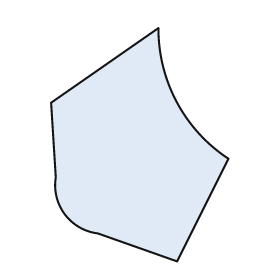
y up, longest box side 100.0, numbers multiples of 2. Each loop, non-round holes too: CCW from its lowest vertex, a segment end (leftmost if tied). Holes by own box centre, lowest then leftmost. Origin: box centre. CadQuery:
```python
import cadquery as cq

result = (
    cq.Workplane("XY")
    .moveTo(16.0, -50.0)
    .lineTo(38.0, -6.0)
    .threePointArc((16.0, 18.0), (8.0, 50.0))
    .lineTo(-38.0, 18.0)
    .lineTo(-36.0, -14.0)
    .threePointArc((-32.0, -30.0), (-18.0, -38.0))
    .close()
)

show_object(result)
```